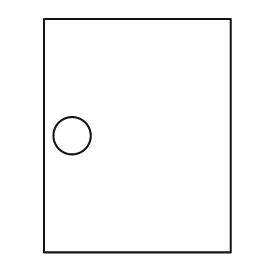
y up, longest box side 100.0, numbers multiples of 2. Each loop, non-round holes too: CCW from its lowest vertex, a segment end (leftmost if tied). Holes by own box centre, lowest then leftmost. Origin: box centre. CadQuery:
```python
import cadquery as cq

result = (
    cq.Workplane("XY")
    .moveTo(-40.0, -50.0)
    .lineTo(40.0, -50.0)
    .lineTo(40.0, 50.0)
    .lineTo(-40.0, 50.0)
    .close()
    .moveTo(-28.0, 0.0)
    .circle(8.0)
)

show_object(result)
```